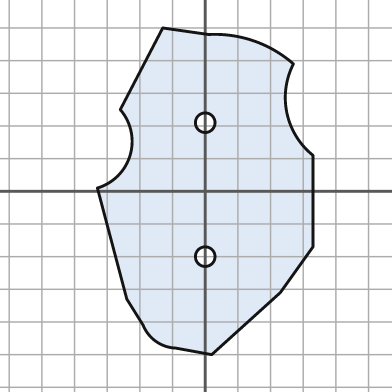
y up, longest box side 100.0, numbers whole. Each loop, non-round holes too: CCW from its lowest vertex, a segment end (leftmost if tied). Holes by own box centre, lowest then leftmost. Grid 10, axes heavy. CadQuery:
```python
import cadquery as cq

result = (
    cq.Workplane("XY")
    .moveTo(2.0, -50.0)
    .lineTo(23.0, -31.0)
    .lineTo(33.0, -17.0)
    .lineTo(33.0, 11.0)
    .threePointArc((25.0, 24.0), (27.0, 39.0))
    .threePointArc((15.0, 46.0), (1.0, 48.0))
    .lineTo(-13.0, 50.0)
    .lineTo(-26.0, 25.0)
    .threePointArc((-23.0, 11.0), (-33.0, 1.0))
    .lineTo(-24.0, -33.0)
    .lineTo(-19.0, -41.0)
    .threePointArc((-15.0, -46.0), (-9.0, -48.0))
    .close()
    .moveTo(0.0, -20.0)
    .circle(3.0)
    .moveTo(0.0, 21.0)
    .circle(3.0)
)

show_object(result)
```